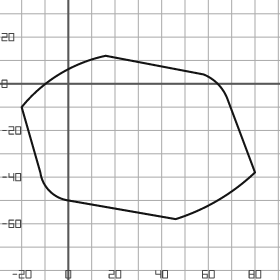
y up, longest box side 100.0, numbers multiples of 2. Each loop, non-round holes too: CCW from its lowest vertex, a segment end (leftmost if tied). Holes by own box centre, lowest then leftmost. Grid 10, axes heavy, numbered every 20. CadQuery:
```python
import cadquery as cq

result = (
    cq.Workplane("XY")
    .moveTo(46.0, -58.0)
    .threePointArc((64.0, -50.0), (80.0, -38.0))
    .lineTo(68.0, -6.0)
    .threePointArc((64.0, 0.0), (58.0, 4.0))
    .lineTo(16.0, 12.0)
    .threePointArc((-4.0, 4.0), (-20.0, -10.0))
    .lineTo(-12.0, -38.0)
    .threePointArc((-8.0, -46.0), (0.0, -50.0))
    .close()
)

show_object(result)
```